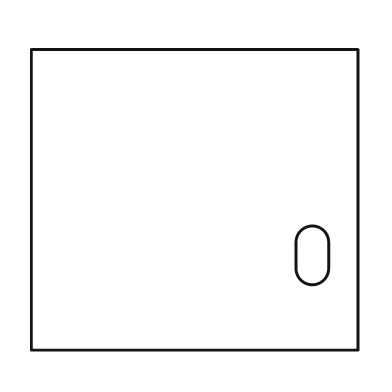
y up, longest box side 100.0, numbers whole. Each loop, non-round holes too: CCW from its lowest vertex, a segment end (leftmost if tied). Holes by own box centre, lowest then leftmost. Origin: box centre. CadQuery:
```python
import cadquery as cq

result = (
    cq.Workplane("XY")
    .moveTo(-50.0, -46.0)
    .lineTo(50.0, -46.0)
    .lineTo(50.0, 46.0)
    .lineTo(-50.0, 46.0)
    .close()
    .moveTo(31.0, -21.0)
    .threePointArc((36.0, -26.0), (41.0, -21.0))
    .lineTo(41.0, -13.0)
    .threePointArc((36.0, -8.0), (31.0, -13.0))
    .close()
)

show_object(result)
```